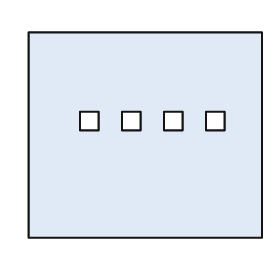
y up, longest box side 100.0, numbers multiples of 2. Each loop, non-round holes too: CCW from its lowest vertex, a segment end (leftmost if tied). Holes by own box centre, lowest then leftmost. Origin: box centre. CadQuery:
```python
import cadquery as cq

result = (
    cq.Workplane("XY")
    .moveTo(-50.0, -44.0)
    .lineTo(50.0, -44.0)
    .lineTo(50.0, 44.0)
    .lineTo(-50.0, 44.0)
    .close()
    .moveTo(-28.0, 2.0)
    .lineTo(-20.0, 2.0)
    .lineTo(-20.0, 10.0)
    .lineTo(-28.0, 10.0)
    .close()
    .moveTo(-10.0, 2.0)
    .lineTo(-2.0, 2.0)
    .lineTo(-2.0, 10.0)
    .lineTo(-10.0, 10.0)
    .close()
    .moveTo(8.0, 2.0)
    .lineTo(16.0, 2.0)
    .lineTo(16.0, 10.0)
    .lineTo(8.0, 10.0)
    .close()
    .moveTo(26.0, 2.0)
    .lineTo(34.0, 2.0)
    .lineTo(34.0, 10.0)
    .lineTo(26.0, 10.0)
    .close()
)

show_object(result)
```